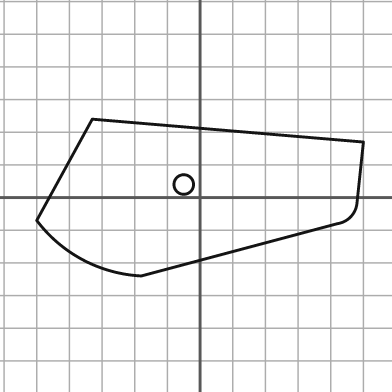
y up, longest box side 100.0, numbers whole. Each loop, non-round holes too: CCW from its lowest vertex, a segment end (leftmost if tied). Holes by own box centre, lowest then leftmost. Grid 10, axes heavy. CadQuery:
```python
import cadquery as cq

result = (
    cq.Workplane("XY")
    .moveTo(-18.0, -24.0)
    .lineTo(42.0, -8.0)
    .threePointArc((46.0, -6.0), (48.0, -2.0))
    .lineTo(50.0, 17.0)
    .lineTo(-33.0, 24.0)
    .lineTo(-50.0, -7.0)
    .threePointArc((-36.0, -19.0), (-18.0, -24.0))
    .close()
    .moveTo(-5.0, 4.0)
    .circle(3.0)
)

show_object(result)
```